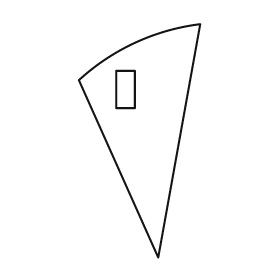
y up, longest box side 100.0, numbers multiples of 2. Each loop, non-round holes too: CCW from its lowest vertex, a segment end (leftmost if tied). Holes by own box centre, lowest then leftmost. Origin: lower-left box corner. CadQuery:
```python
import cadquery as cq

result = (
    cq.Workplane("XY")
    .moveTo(34.0, 0.0)
    .lineTo(52.0, 100.0)
    .threePointArc((24.0, 92.0), (0.0, 76.0))
    .close()
    .moveTo(16.0, 64.0)
    .lineTo(24.0, 64.0)
    .lineTo(24.0, 80.0)
    .lineTo(16.0, 80.0)
    .close()
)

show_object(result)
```